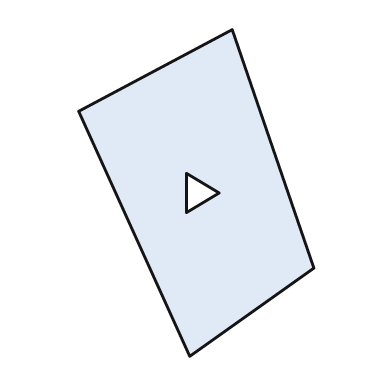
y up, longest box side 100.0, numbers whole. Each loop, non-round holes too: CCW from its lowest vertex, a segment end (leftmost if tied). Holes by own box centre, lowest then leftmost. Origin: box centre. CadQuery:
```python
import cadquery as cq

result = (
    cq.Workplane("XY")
    .moveTo(-2.0, -50.0)
    .lineTo(36.0, -23.0)
    .lineTo(11.0, 50.0)
    .lineTo(-36.0, 25.0)
    .close()
    .moveTo(-3.0, -6.0)
    .lineTo(7.0, 0.0)
    .lineTo(-3.0, 6.0)
    .close()
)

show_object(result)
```